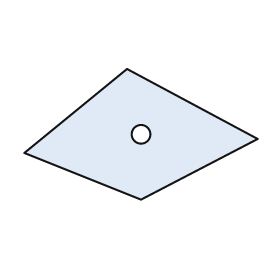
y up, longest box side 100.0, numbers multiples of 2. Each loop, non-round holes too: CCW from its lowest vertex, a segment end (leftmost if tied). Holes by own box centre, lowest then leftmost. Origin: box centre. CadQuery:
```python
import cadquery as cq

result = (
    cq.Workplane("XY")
    .moveTo(0.0, -28.0)
    .lineTo(50.0, -2.0)
    .lineTo(-6.0, 28.0)
    .lineTo(-50.0, -8.0)
    .close()
    .moveTo(0.0, 0.0)
    .circle(4.0)
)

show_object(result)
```